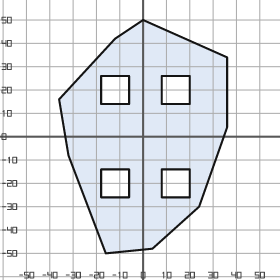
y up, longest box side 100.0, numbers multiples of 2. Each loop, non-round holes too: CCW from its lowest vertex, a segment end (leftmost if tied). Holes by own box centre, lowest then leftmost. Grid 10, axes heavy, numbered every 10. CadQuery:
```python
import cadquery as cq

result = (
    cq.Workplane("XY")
    .moveTo(-16.0, -50.0)
    .lineTo(4.0, -48.0)
    .lineTo(24.0, -30.0)
    .lineTo(36.0, 4.0)
    .lineTo(36.0, 34.0)
    .lineTo(0.0, 50.0)
    .lineTo(-12.0, 42.0)
    .lineTo(-36.0, 16.0)
    .lineTo(-32.0, -8.0)
    .close()
    .moveTo(-18.0, -26.0)
    .lineTo(-6.0, -26.0)
    .lineTo(-6.0, -14.0)
    .lineTo(-18.0, -14.0)
    .close()
    .moveTo(8.0, -26.0)
    .lineTo(20.0, -26.0)
    .lineTo(20.0, -14.0)
    .lineTo(8.0, -14.0)
    .close()
    .moveTo(-18.0, 14.0)
    .lineTo(-6.0, 14.0)
    .lineTo(-6.0, 26.0)
    .lineTo(-18.0, 26.0)
    .close()
    .moveTo(8.0, 14.0)
    .lineTo(20.0, 14.0)
    .lineTo(20.0, 26.0)
    .lineTo(8.0, 26.0)
    .close()
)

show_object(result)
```